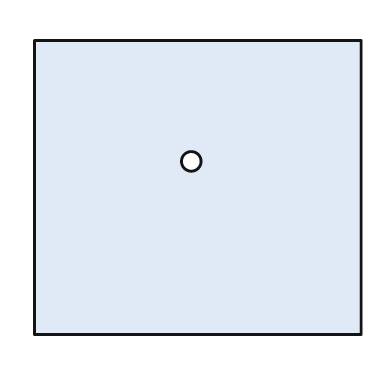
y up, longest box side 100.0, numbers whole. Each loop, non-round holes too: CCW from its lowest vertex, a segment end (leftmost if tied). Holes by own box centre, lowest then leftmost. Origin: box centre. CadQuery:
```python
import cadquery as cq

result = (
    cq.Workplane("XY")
    .moveTo(-50.0, -45.0)
    .lineTo(50.0, -45.0)
    .lineTo(50.0, 45.0)
    .lineTo(-50.0, 45.0)
    .close()
    .moveTo(-2.0, 8.0)
    .circle(3.0)
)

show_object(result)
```